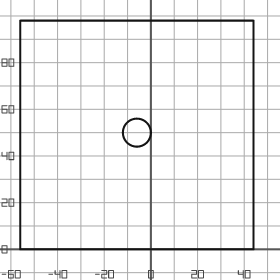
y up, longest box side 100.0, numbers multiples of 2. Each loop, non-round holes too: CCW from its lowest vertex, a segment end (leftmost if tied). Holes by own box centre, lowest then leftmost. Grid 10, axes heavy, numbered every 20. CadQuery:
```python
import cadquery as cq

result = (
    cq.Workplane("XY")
    .moveTo(-56.0, 0.0)
    .lineTo(44.0, 0.0)
    .lineTo(44.0, 98.0)
    .lineTo(-56.0, 98.0)
    .close()
    .moveTo(-6.0, 50.0)
    .circle(6.0)
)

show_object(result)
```